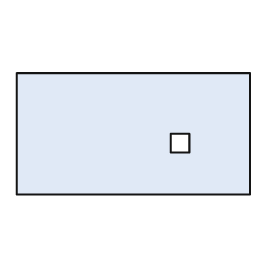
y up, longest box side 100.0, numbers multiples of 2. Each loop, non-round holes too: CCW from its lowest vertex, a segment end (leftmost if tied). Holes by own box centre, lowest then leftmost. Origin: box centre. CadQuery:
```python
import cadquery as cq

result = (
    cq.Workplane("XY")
    .moveTo(-50.0, -26.0)
    .lineTo(50.0, -26.0)
    .lineTo(50.0, 26.0)
    .lineTo(-50.0, 26.0)
    .close()
    .moveTo(16.0, -8.0)
    .lineTo(24.0, -8.0)
    .lineTo(24.0, 0.0)
    .lineTo(16.0, 0.0)
    .close()
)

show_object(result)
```